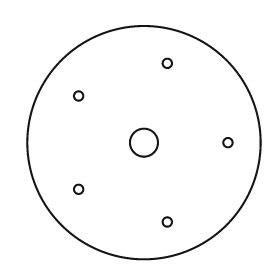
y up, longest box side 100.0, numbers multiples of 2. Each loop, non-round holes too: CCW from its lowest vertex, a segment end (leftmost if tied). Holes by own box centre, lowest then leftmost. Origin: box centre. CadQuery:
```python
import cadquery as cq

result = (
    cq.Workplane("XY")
    .moveTo(0.0, 0.0)
    .circle(50.0)
    .moveTo(10.0, -34.0)
    .circle(2.0)
    .moveTo(-28.0, -20.0)
    .circle(2.0)
    .moveTo(0.0, 0.0)
    .circle(6.0)
    .moveTo(36.0, 0.0)
    .circle(2.0)
    .moveTo(-28.0, 20.0)
    .circle(2.0)
    .moveTo(10.0, 34.0)
    .circle(2.0)
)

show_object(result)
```